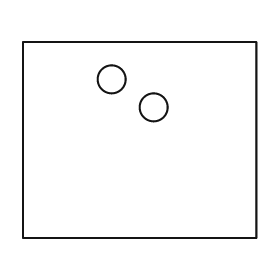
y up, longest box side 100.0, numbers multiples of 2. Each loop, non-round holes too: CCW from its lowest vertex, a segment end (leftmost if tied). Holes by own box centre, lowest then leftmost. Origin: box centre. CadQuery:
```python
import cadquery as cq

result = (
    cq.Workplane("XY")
    .moveTo(-50.0, -42.0)
    .lineTo(50.0, -42.0)
    .lineTo(50.0, 42.0)
    .lineTo(-50.0, 42.0)
    .close()
    .moveTo(6.0, 14.0)
    .circle(6.0)
    .moveTo(-12.0, 26.0)
    .circle(6.0)
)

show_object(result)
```